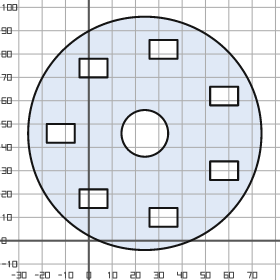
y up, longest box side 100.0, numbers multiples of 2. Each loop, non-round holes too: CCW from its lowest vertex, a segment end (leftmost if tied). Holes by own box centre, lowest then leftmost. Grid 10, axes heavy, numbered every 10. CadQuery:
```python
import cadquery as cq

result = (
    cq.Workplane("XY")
    .moveTo(24.0, 46.0)
    .circle(50.0)
    .moveTo(26.0, 6.0)
    .lineTo(38.0, 6.0)
    .lineTo(38.0, 14.0)
    .lineTo(26.0, 14.0)
    .close()
    .moveTo(-4.0, 14.0)
    .lineTo(8.0, 14.0)
    .lineTo(8.0, 22.0)
    .lineTo(-4.0, 22.0)
    .close()
    .moveTo(52.0, 26.0)
    .lineTo(64.0, 26.0)
    .lineTo(64.0, 34.0)
    .lineTo(52.0, 34.0)
    .close()
    .moveTo(-18.0, 42.0)
    .lineTo(-6.0, 42.0)
    .lineTo(-6.0, 50.0)
    .lineTo(-18.0, 50.0)
    .close()
    .moveTo(24.0, 46.0)
    .circle(10.0)
    .moveTo(52.0, 58.0)
    .lineTo(64.0, 58.0)
    .lineTo(64.0, 66.0)
    .lineTo(52.0, 66.0)
    .close()
    .moveTo(-4.0, 70.0)
    .lineTo(8.0, 70.0)
    .lineTo(8.0, 78.0)
    .lineTo(-4.0, 78.0)
    .close()
    .moveTo(26.0, 78.0)
    .lineTo(38.0, 78.0)
    .lineTo(38.0, 86.0)
    .lineTo(26.0, 86.0)
    .close()
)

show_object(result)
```